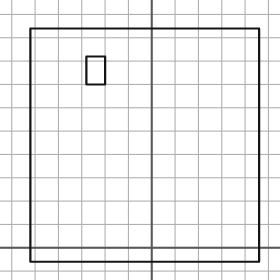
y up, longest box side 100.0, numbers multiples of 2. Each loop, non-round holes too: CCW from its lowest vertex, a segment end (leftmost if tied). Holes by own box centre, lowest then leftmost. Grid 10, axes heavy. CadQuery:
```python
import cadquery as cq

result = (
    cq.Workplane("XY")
    .moveTo(-52.0, -6.0)
    .lineTo(46.0, -6.0)
    .lineTo(46.0, 94.0)
    .lineTo(-52.0, 94.0)
    .close()
    .moveTo(-28.0, 70.0)
    .lineTo(-20.0, 70.0)
    .lineTo(-20.0, 82.0)
    .lineTo(-28.0, 82.0)
    .close()
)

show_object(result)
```